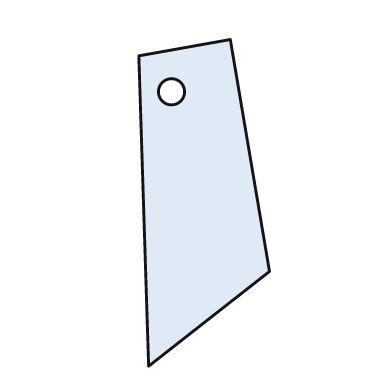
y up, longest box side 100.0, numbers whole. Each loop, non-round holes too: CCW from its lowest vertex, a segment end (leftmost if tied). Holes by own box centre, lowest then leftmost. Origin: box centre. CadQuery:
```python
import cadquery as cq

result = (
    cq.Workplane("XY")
    .moveTo(-17.0, -50.0)
    .lineTo(20.0, -21.0)
    .lineTo(8.0, 50.0)
    .lineTo(-20.0, 45.0)
    .close()
    .moveTo(-10.0, 34.0)
    .circle(4.0)
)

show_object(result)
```